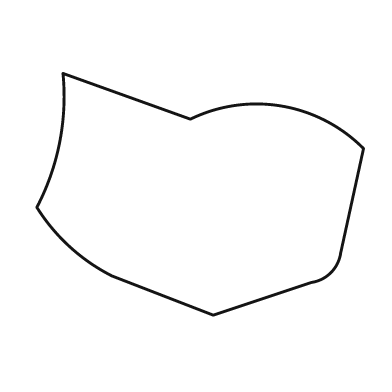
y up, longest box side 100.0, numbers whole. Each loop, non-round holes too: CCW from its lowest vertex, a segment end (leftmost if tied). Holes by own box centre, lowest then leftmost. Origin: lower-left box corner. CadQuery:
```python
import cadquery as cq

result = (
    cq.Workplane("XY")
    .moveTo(54.0, 0.0)
    .lineTo(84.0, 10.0)
    .threePointArc((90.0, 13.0), (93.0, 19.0))
    .lineTo(100.0, 51.0)
    .threePointArc((75.0, 64.0), (47.0, 60.0))
    .lineTo(8.0, 74.0)
    .threePointArc((7.0, 53.0), (0.0, 33.0))
    .threePointArc((10.0, 21.0), (23.0, 12.0))
    .close()
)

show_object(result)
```